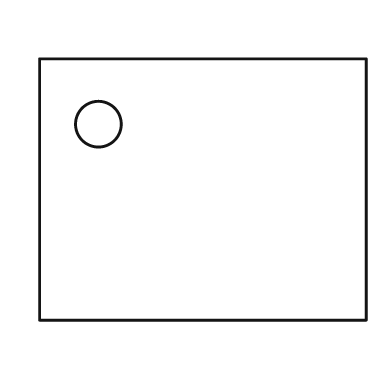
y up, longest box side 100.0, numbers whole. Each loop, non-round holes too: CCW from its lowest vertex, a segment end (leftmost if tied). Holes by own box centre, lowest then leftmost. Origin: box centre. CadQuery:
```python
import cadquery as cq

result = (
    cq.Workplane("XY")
    .moveTo(-50.0, -40.0)
    .lineTo(50.0, -40.0)
    .lineTo(50.0, 40.0)
    .lineTo(-50.0, 40.0)
    .close()
    .moveTo(-32.0, 20.0)
    .circle(7.0)
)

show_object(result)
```